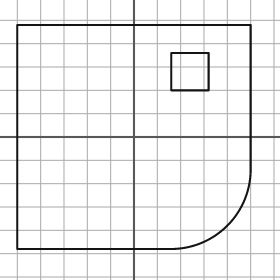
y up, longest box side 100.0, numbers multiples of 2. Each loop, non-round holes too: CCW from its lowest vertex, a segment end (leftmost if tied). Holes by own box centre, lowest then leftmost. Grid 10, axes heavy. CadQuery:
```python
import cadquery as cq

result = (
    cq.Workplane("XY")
    .moveTo(-50.0, -48.0)
    .lineTo(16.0, -48.0)
    .threePointArc((40.0, -38.0), (50.0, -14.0))
    .lineTo(50.0, 48.0)
    .lineTo(-50.0, 48.0)
    .close()
    .moveTo(16.0, 20.0)
    .lineTo(32.0, 20.0)
    .lineTo(32.0, 36.0)
    .lineTo(16.0, 36.0)
    .close()
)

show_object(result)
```